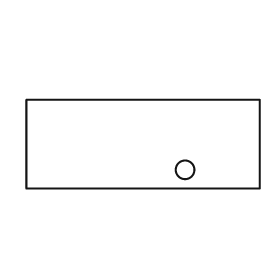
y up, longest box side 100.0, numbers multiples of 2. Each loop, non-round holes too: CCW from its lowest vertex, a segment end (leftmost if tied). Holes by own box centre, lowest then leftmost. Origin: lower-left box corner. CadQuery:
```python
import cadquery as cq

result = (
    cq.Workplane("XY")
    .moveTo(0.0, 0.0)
    .lineTo(100.0, 0.0)
    .lineTo(100.0, 38.0)
    .lineTo(0.0, 38.0)
    .close()
    .moveTo(68.0, 8.0)
    .circle(4.0)
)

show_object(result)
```